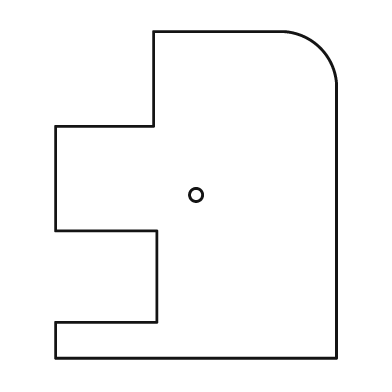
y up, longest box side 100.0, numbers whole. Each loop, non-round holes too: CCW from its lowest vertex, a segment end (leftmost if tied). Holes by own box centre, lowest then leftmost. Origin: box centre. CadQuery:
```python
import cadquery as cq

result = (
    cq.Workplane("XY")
    .moveTo(-43.0, -50.0)
    .lineTo(43.0, -50.0)
    .lineTo(43.0, 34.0)
    .threePointArc((38.0, 45.0), (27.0, 50.0))
    .lineTo(-13.0, 50.0)
    .lineTo(-13.0, 21.0)
    .lineTo(-43.0, 21.0)
    .lineTo(-43.0, -11.0)
    .lineTo(-12.0, -11.0)
    .lineTo(-12.0, -39.0)
    .lineTo(-43.0, -39.0)
    .close()
    .moveTo(0.0, 0.0)
    .circle(2.0)
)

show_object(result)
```